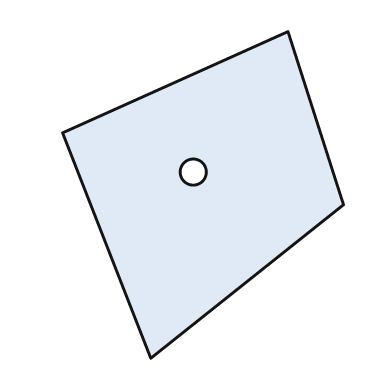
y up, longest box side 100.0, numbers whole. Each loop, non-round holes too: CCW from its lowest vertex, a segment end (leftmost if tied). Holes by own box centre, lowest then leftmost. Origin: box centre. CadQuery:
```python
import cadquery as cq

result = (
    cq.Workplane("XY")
    .moveTo(-16.0, -50.0)
    .lineTo(43.0, -3.0)
    .lineTo(26.0, 50.0)
    .lineTo(-43.0, 19.0)
    .close()
    .moveTo(-3.0, 7.0)
    .circle(4.0)
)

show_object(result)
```